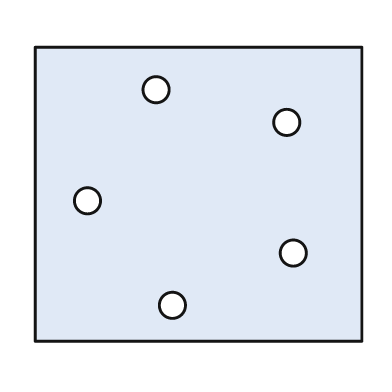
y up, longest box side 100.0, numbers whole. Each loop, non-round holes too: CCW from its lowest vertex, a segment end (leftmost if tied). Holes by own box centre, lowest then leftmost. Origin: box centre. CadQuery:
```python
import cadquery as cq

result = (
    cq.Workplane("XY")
    .moveTo(-50.0, -45.0)
    .lineTo(50.0, -45.0)
    .lineTo(50.0, 45.0)
    .lineTo(-50.0, 45.0)
    .close()
    .moveTo(-8.0, -34.0)
    .circle(4.0)
    .moveTo(29.0, -18.0)
    .circle(4.0)
    .moveTo(-34.0, -2.0)
    .circle(4.0)
    .moveTo(27.0, 22.0)
    .circle(4.0)
    .moveTo(-13.0, 32.0)
    .circle(4.0)
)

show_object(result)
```